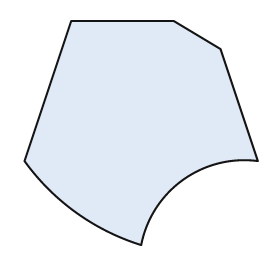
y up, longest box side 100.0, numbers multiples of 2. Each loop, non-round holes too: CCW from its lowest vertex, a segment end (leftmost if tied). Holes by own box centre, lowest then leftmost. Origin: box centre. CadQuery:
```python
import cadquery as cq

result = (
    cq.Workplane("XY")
    .moveTo(0.0, -48.0)
    .threePointArc((18.0, -20.0), (50.0, -12.0))
    .lineTo(34.0, 36.0)
    .lineTo(14.0, 48.0)
    .lineTo(-30.0, 48.0)
    .lineTo(-50.0, -12.0)
    .threePointArc((-28.0, -34.0), (0.0, -48.0))
    .close()
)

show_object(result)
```